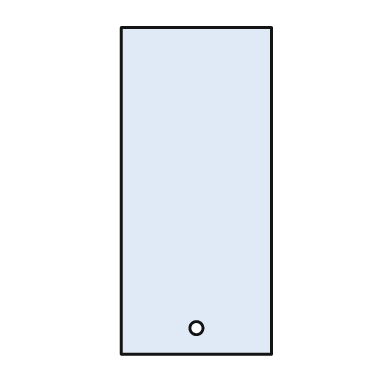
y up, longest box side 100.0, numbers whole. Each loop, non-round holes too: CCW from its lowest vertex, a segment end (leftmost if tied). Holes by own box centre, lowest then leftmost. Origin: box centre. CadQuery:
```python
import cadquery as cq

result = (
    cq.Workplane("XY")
    .moveTo(-23.0, -50.0)
    .lineTo(23.0, -50.0)
    .lineTo(23.0, 50.0)
    .lineTo(-23.0, 50.0)
    .close()
    .moveTo(0.0, -42.0)
    .circle(2.0)
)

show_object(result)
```